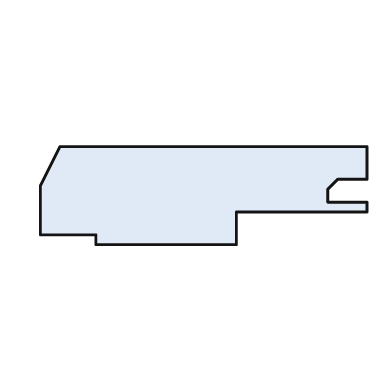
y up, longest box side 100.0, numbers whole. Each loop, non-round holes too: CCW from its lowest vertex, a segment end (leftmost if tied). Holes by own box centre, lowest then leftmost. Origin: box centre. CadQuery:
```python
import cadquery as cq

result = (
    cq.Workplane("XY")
    .moveTo(-33.0, -15.0)
    .lineTo(10.0, -15.0)
    .lineTo(10.0, -5.0)
    .lineTo(50.0, -5.0)
    .lineTo(50.0, -2.0)
    .lineTo(38.0, -2.0)
    .lineTo(38.0, 2.0)
    .lineTo(41.0, 5.0)
    .lineTo(50.0, 5.0)
    .lineTo(50.0, 15.0)
    .lineTo(-44.0, 15.0)
    .lineTo(-50.0, 3.0)
    .lineTo(-50.0, -12.0)
    .lineTo(-33.0, -12.0)
    .close()
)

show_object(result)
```